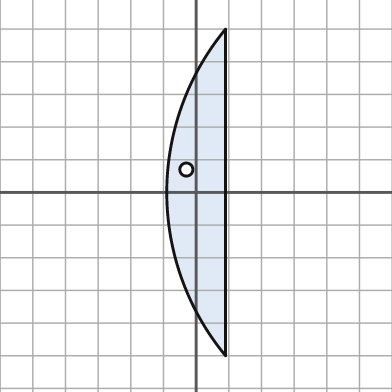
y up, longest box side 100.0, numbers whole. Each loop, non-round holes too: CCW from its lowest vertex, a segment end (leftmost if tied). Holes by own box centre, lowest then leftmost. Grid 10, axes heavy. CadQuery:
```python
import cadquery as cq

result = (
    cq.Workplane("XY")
    .moveTo(9.0, -50.0)
    .lineTo(9.0, 50.0)
    .threePointArc((-9.0, 0.0), (9.0, -50.0))
    .close()
    .moveTo(-3.0, 7.0)
    .circle(2.0)
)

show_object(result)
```